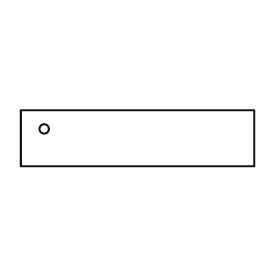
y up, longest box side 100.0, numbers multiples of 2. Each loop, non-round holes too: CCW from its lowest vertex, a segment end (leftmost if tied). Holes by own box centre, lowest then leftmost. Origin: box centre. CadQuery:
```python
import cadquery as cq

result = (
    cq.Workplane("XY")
    .moveTo(-50.0, -12.0)
    .lineTo(50.0, -12.0)
    .lineTo(50.0, 12.0)
    .lineTo(-50.0, 12.0)
    .close()
    .moveTo(-40.0, 4.0)
    .circle(2.0)
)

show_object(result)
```